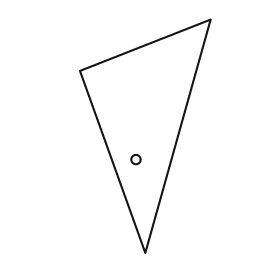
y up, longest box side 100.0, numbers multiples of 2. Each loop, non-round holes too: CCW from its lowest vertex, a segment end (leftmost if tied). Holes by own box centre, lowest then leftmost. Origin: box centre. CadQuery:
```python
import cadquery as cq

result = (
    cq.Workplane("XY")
    .moveTo(0.0, -50.0)
    .lineTo(28.0, 50.0)
    .lineTo(-28.0, 28.0)
    .close()
    .moveTo(-4.0, -10.0)
    .circle(2.0)
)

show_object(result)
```